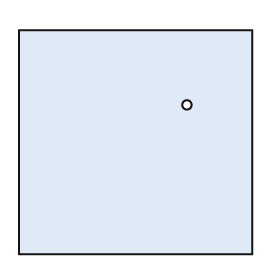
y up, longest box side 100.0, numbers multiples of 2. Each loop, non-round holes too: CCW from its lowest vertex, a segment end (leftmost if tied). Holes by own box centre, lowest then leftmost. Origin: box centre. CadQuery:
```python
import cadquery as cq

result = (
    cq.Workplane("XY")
    .moveTo(-50.0, -48.0)
    .lineTo(50.0, -48.0)
    .lineTo(50.0, 48.0)
    .lineTo(-50.0, 48.0)
    .close()
    .moveTo(22.0, 16.0)
    .circle(2.0)
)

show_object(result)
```